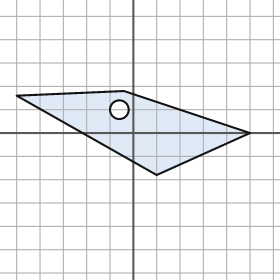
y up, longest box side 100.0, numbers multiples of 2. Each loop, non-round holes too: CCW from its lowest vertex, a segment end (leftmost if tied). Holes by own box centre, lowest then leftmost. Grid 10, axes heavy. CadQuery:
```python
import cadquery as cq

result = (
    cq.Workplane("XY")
    .moveTo(10.0, -18.0)
    .lineTo(50.0, 0.0)
    .lineTo(-4.0, 18.0)
    .lineTo(-50.0, 16.0)
    .close()
    .moveTo(-6.0, 10.0)
    .circle(4.0)
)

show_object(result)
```